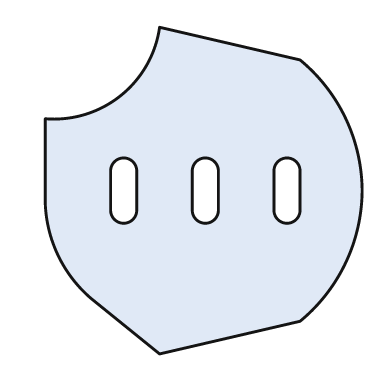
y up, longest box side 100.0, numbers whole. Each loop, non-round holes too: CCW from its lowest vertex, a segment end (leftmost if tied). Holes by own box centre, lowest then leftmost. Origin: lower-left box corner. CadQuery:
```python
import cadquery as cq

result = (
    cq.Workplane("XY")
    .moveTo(35.0, 0.0)
    .lineTo(78.0, 10.0)
    .threePointArc((92.0, 28.0), (97.0, 50.0))
    .threePointArc((92.0, 72.0), (78.0, 90.0))
    .lineTo(35.0, 100.0)
    .threePointArc((23.0, 79.0), (0.0, 72.0))
    .lineTo(0.0, 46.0)
    .threePointArc((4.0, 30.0), (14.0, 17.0))
    .close()
    .moveTo(20.0, 44.0)
    .threePointArc((24.0, 40.0), (28.0, 44.0))
    .lineTo(28.0, 56.0)
    .threePointArc((24.0, 60.0), (20.0, 56.0))
    .close()
    .moveTo(45.0, 44.0)
    .threePointArc((49.0, 40.0), (53.0, 44.0))
    .lineTo(53.0, 56.0)
    .threePointArc((49.0, 60.0), (45.0, 56.0))
    .close()
    .moveTo(70.0, 44.0)
    .threePointArc((74.0, 40.0), (78.0, 44.0))
    .lineTo(78.0, 56.0)
    .threePointArc((74.0, 60.0), (70.0, 56.0))
    .close()
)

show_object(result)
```